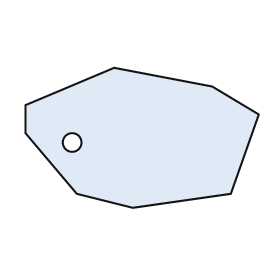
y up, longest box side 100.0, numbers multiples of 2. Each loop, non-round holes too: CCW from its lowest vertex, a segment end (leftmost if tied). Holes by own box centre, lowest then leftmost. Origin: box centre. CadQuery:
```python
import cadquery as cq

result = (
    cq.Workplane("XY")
    .moveTo(-4.0, -30.0)
    .lineTo(38.0, -24.0)
    .lineTo(50.0, 10.0)
    .lineTo(30.0, 22.0)
    .lineTo(-12.0, 30.0)
    .lineTo(-50.0, 14.0)
    .lineTo(-50.0, 2.0)
    .lineTo(-28.0, -24.0)
    .close()
    .moveTo(-30.0, -2.0)
    .circle(4.0)
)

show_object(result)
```